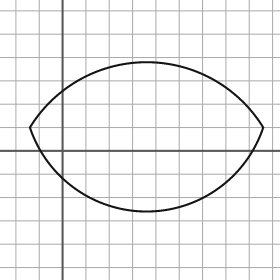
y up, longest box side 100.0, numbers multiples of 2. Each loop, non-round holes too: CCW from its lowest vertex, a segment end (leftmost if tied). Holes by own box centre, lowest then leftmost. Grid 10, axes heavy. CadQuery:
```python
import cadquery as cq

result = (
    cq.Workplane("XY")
    .moveTo(-14.0, 10.0)
    .threePointArc((36.0, -26.0), (86.0, 10.0))
    .threePointArc((36.0, 38.0), (-14.0, 10.0))
    .close()
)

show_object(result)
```